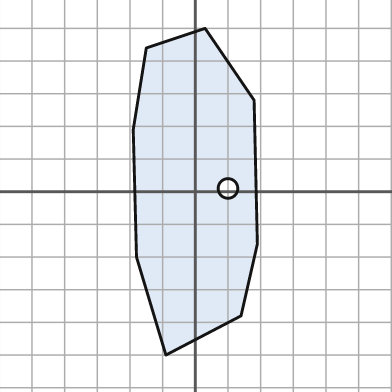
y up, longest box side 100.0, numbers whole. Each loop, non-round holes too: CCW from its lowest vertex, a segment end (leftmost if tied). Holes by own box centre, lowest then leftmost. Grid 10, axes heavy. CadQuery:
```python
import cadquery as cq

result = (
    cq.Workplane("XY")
    .moveTo(-9.0, -50.0)
    .lineTo(14.0, -38.0)
    .lineTo(19.0, -16.0)
    .lineTo(18.0, 28.0)
    .lineTo(3.0, 50.0)
    .lineTo(-15.0, 44.0)
    .lineTo(-19.0, 19.0)
    .lineTo(-18.0, -20.0)
    .close()
    .moveTo(10.0, 1.0)
    .circle(3.0)
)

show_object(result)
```